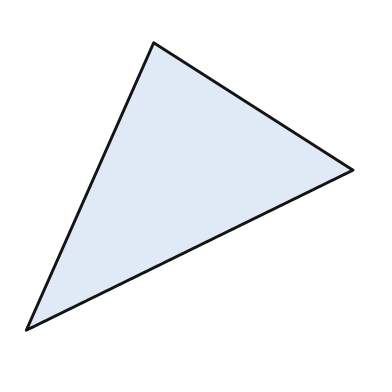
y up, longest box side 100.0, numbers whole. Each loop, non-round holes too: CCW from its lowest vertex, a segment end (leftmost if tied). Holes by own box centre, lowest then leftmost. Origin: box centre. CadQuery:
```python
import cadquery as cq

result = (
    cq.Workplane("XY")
    .moveTo(-50.0, -44.0)
    .lineTo(50.0, 5.0)
    .lineTo(-11.0, 44.0)
    .close()
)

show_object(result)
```